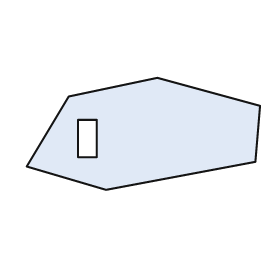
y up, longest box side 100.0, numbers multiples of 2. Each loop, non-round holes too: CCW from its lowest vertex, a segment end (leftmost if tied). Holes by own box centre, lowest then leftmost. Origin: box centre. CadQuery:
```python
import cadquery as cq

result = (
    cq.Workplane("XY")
    .moveTo(-16.0, -24.0)
    .lineTo(48.0, -12.0)
    .lineTo(50.0, 12.0)
    .lineTo(6.0, 24.0)
    .lineTo(-32.0, 16.0)
    .lineTo(-50.0, -14.0)
    .close()
    .moveTo(-28.0, -10.0)
    .lineTo(-20.0, -10.0)
    .lineTo(-20.0, 6.0)
    .lineTo(-28.0, 6.0)
    .close()
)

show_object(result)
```